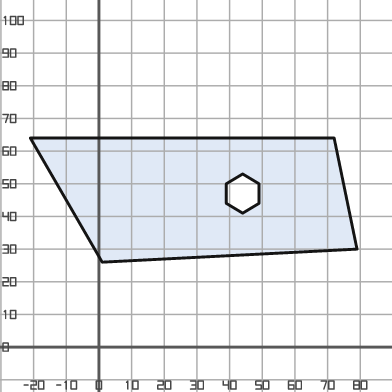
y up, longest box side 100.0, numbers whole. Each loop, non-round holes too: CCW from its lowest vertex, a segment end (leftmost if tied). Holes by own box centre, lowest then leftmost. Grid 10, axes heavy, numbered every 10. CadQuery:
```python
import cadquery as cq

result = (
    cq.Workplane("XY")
    .moveTo(1.0, 26.0)
    .lineTo(79.0, 30.0)
    .lineTo(72.0, 64.0)
    .lineTo(-21.0, 64.0)
    .close()
    .moveTo(44.0, 41.0)
    .lineTo(49.0, 44.0)
    .lineTo(49.0, 50.0)
    .lineTo(44.0, 53.0)
    .lineTo(39.0, 50.0)
    .lineTo(39.0, 44.0)
    .close()
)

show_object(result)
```